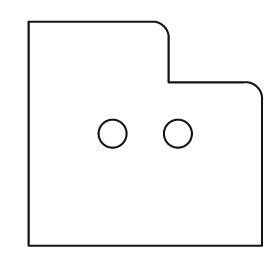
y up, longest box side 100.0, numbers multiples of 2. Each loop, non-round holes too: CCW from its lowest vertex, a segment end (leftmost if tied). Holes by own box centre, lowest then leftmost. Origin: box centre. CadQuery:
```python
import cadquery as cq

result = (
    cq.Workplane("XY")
    .moveTo(-50.0, -48.0)
    .lineTo(50.0, -48.0)
    .lineTo(50.0, 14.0)
    .threePointArc((48.0, 20.0), (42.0, 22.0))
    .lineTo(10.0, 22.0)
    .lineTo(10.0, 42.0)
    .threePointArc((8.0, 46.0), (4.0, 48.0))
    .lineTo(-50.0, 48.0)
    .close()
    .moveTo(-14.0, 0.0)
    .circle(6.0)
    .moveTo(14.0, 0.0)
    .circle(6.0)
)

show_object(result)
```